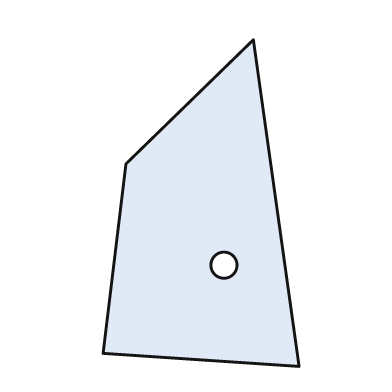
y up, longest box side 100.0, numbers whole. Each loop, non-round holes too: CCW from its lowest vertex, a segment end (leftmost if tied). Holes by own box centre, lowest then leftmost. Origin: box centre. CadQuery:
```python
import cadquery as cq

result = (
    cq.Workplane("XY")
    .moveTo(30.0, -50.0)
    .lineTo(16.0, 50.0)
    .lineTo(-23.0, 12.0)
    .lineTo(-30.0, -46.0)
    .close()
    .moveTo(7.0, -19.0)
    .circle(4.0)
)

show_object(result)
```